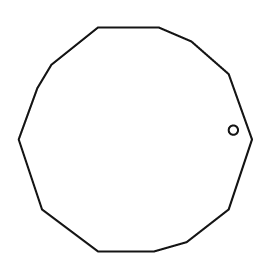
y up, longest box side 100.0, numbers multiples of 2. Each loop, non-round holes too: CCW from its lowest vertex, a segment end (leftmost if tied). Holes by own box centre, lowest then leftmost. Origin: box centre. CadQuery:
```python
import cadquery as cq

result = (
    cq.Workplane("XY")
    .moveTo(-16.0, -48.0)
    .lineTo(8.0, -48.0)
    .lineTo(22.0, -44.0)
    .lineTo(40.0, -30.0)
    .lineTo(50.0, 0.0)
    .lineTo(40.0, 28.0)
    .lineTo(24.0, 42.0)
    .lineTo(10.0, 48.0)
    .lineTo(-16.0, 48.0)
    .lineTo(-36.0, 32.0)
    .lineTo(-42.0, 22.0)
    .lineTo(-50.0, 0.0)
    .lineTo(-40.0, -30.0)
    .close()
    .moveTo(42.0, 4.0)
    .circle(2.0)
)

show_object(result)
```